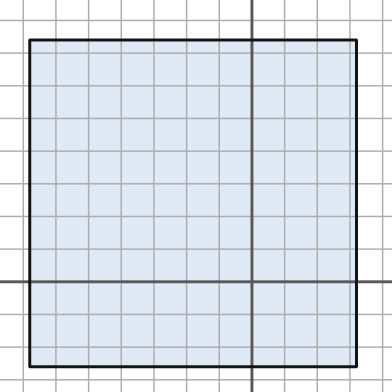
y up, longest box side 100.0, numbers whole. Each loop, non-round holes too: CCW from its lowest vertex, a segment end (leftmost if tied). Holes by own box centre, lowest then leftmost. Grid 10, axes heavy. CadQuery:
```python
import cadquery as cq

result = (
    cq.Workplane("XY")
    .moveTo(-68.0, -26.0)
    .lineTo(32.0, -26.0)
    .lineTo(32.0, 74.0)
    .lineTo(-68.0, 74.0)
    .close()
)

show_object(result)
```